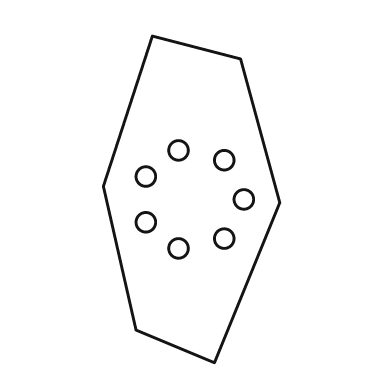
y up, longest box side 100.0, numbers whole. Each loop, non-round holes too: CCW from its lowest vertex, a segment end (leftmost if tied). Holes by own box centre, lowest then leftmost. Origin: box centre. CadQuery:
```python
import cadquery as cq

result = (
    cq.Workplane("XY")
    .moveTo(7.0, -50.0)
    .lineTo(27.0, -1.0)
    .lineTo(15.0, 43.0)
    .lineTo(-12.0, 50.0)
    .lineTo(-27.0, 4.0)
    .lineTo(-17.0, -40.0)
    .close()
    .moveTo(-4.0, -15.0)
    .circle(3.0)
    .moveTo(10.0, -12.0)
    .circle(3.0)
    .moveTo(-14.0, -7.0)
    .circle(3.0)
    .moveTo(16.0, 0.0)
    .circle(3.0)
    .moveTo(-14.0, 7.0)
    .circle(3.0)
    .moveTo(10.0, 12.0)
    .circle(3.0)
    .moveTo(-4.0, 15.0)
    .circle(3.0)
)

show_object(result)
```